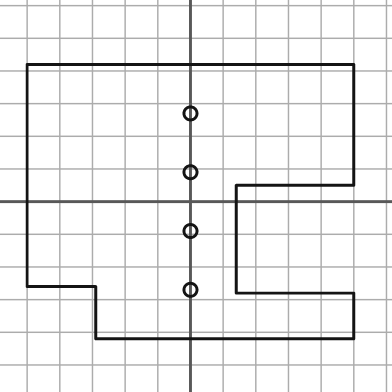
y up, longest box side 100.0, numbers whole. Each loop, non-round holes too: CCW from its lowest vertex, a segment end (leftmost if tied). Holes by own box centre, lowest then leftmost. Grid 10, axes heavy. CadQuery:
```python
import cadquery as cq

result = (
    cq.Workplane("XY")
    .moveTo(-29.0, -42.0)
    .lineTo(50.0, -42.0)
    .lineTo(50.0, -28.0)
    .lineTo(14.0, -28.0)
    .lineTo(14.0, 5.0)
    .lineTo(50.0, 5.0)
    .lineTo(50.0, 42.0)
    .lineTo(-50.0, 42.0)
    .lineTo(-50.0, -26.0)
    .lineTo(-29.0, -26.0)
    .close()
    .moveTo(0.0, -27.0)
    .circle(2.0)
    .moveTo(0.0, -9.0)
    .circle(2.0)
    .moveTo(0.0, 9.0)
    .circle(2.0)
    .moveTo(0.0, 27.0)
    .circle(2.0)
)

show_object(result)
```